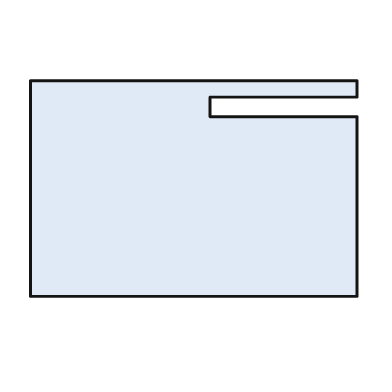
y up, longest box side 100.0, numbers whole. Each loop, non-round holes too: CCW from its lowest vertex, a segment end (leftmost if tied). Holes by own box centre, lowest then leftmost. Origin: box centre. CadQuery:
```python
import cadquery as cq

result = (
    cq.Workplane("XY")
    .moveTo(-50.0, -33.0)
    .lineTo(50.0, -33.0)
    .lineTo(50.0, 22.0)
    .lineTo(5.0, 22.0)
    .lineTo(5.0, 28.0)
    .lineTo(50.0, 28.0)
    .lineTo(50.0, 33.0)
    .lineTo(-50.0, 33.0)
    .close()
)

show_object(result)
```